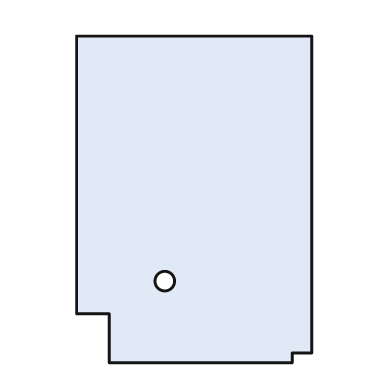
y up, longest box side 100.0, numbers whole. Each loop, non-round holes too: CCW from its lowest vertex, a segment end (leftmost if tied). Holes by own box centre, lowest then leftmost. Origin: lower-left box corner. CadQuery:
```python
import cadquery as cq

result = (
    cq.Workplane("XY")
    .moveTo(10.0, 0.0)
    .lineTo(66.0, 0.0)
    .lineTo(66.0, 3.0)
    .lineTo(72.0, 3.0)
    .lineTo(72.0, 100.0)
    .lineTo(0.0, 100.0)
    .lineTo(0.0, 15.0)
    .lineTo(10.0, 15.0)
    .close()
    .moveTo(27.0, 25.0)
    .circle(3.0)
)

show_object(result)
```